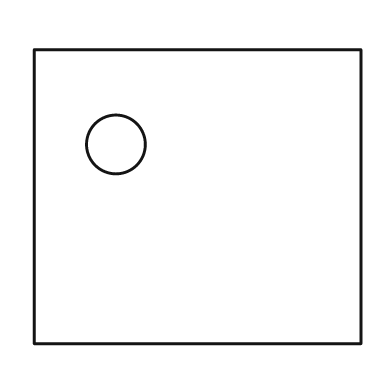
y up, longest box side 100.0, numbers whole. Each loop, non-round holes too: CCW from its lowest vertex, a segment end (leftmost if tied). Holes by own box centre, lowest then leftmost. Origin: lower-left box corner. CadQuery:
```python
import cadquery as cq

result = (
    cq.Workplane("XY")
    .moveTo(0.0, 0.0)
    .lineTo(100.0, 0.0)
    .lineTo(100.0, 90.0)
    .lineTo(0.0, 90.0)
    .close()
    .moveTo(25.0, 61.0)
    .circle(9.0)
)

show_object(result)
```